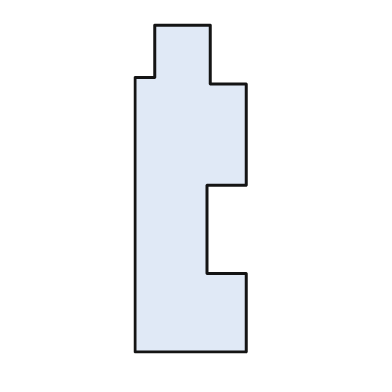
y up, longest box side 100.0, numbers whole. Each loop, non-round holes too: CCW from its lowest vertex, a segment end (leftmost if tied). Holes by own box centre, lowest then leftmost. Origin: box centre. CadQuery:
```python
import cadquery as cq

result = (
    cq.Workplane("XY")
    .moveTo(-17.0, -50.0)
    .lineTo(17.0, -50.0)
    .lineTo(17.0, -26.0)
    .lineTo(5.0, -26.0)
    .lineTo(5.0, 1.0)
    .lineTo(17.0, 1.0)
    .lineTo(17.0, 32.0)
    .lineTo(6.0, 32.0)
    .lineTo(6.0, 50.0)
    .lineTo(-11.0, 50.0)
    .lineTo(-11.0, 34.0)
    .lineTo(-17.0, 34.0)
    .close()
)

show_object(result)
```